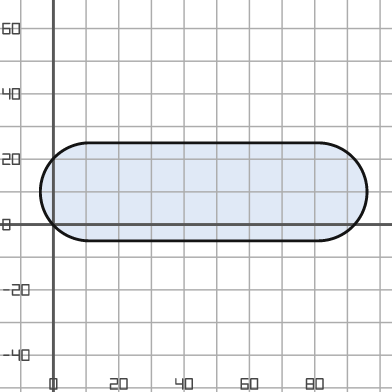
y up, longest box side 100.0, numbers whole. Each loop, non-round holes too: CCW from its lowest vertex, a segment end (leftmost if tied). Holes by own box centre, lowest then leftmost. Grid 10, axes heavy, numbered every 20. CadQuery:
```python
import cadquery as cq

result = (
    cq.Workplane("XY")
    .moveTo(11.0, -5.0)
    .lineTo(81.0, -5.0)
    .threePointArc((96.0, 10.0), (81.0, 25.0))
    .lineTo(11.0, 25.0)
    .threePointArc((-4.0, 10.0), (11.0, -5.0))
    .close()
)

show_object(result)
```